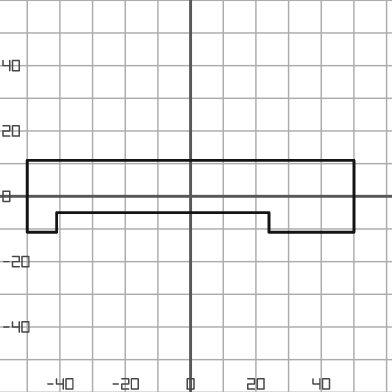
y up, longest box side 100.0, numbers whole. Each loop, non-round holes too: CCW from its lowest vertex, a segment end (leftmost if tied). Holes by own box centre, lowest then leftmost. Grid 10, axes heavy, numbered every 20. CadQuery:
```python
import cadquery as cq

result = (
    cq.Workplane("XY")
    .moveTo(-50.0, -11.0)
    .lineTo(-41.0, -11.0)
    .lineTo(-41.0, -5.0)
    .lineTo(24.0, -5.0)
    .lineTo(24.0, -11.0)
    .lineTo(50.0, -11.0)
    .lineTo(50.0, 11.0)
    .lineTo(-50.0, 11.0)
    .close()
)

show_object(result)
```